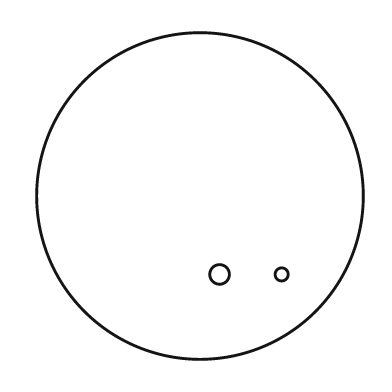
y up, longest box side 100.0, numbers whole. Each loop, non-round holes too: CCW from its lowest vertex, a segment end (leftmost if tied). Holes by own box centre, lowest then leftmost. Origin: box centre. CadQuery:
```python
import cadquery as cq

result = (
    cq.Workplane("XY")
    .moveTo(0.0, 0.0)
    .circle(50.0)
    .moveTo(6.0, -24.0)
    .circle(3.0)
    .moveTo(25.0, -24.0)
    .circle(2.0)
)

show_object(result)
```